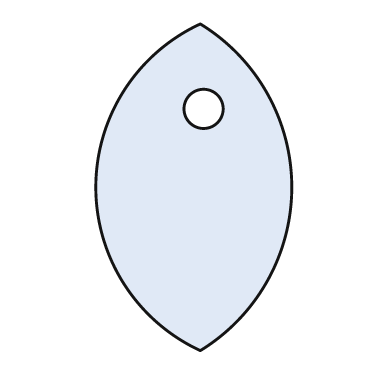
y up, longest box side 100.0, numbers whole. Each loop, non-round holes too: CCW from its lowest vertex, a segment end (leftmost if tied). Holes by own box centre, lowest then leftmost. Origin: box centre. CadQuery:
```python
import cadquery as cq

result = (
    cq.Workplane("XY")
    .moveTo(2.0, -50.0)
    .threePointArc((30.0, 0.0), (2.0, 50.0))
    .threePointArc((-30.0, 0.0), (2.0, -50.0))
    .close()
    .moveTo(3.0, 24.0)
    .circle(6.0)
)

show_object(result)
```